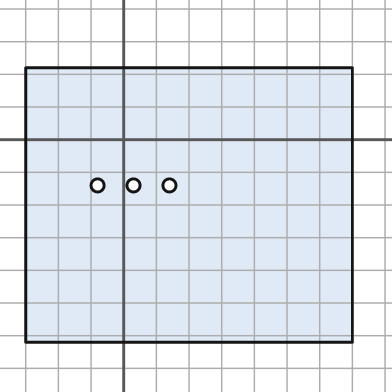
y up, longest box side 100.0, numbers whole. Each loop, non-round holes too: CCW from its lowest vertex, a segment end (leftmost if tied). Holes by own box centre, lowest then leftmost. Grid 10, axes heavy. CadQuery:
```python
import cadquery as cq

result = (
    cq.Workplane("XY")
    .moveTo(-30.0, -62.0)
    .lineTo(70.0, -62.0)
    .lineTo(70.0, 22.0)
    .lineTo(-30.0, 22.0)
    .close()
    .moveTo(-8.0, -14.0)
    .circle(2.0)
    .moveTo(3.0, -14.0)
    .circle(2.0)
    .moveTo(14.0, -14.0)
    .circle(2.0)
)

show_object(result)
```